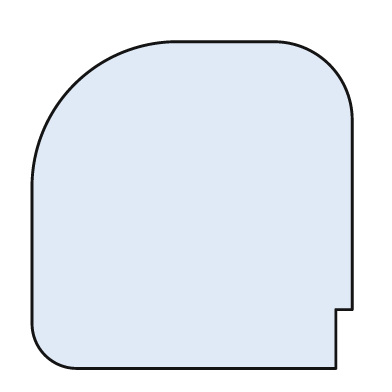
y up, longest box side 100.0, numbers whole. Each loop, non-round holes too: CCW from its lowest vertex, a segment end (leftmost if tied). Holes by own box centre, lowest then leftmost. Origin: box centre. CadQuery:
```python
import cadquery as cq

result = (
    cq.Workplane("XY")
    .moveTo(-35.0, -50.0)
    .lineTo(44.0, -50.0)
    .lineTo(44.0, -32.0)
    .lineTo(49.0, -32.0)
    .lineTo(49.0, 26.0)
    .threePointArc((42.0, 43.0), (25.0, 50.0))
    .lineTo(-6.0, 50.0)
    .threePointArc((-36.0, 37.0), (-49.0, 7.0))
    .lineTo(-49.0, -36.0)
    .threePointArc((-45.0, -46.0), (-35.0, -50.0))
    .close()
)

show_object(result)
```